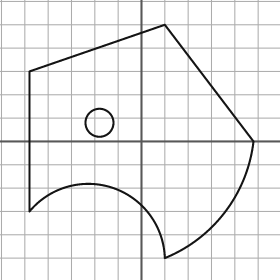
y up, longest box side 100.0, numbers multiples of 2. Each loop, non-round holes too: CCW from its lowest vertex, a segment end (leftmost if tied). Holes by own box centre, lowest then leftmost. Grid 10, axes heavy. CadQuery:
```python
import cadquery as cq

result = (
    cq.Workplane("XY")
    .moveTo(10.0, -50.0)
    .threePointArc((36.0, -30.0), (48.0, 0.0))
    .lineTo(10.0, 50.0)
    .lineTo(-48.0, 30.0)
    .lineTo(-48.0, -30.0)
    .threePointArc((-12.0, -20.0), (10.0, -50.0))
    .close()
    .moveTo(-18.0, 8.0)
    .circle(6.0)
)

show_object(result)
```